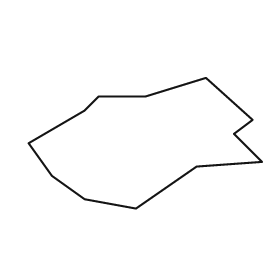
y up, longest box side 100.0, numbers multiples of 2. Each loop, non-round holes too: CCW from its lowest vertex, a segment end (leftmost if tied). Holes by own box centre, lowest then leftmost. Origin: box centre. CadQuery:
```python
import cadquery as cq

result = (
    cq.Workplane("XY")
    .moveTo(-4.0, -28.0)
    .lineTo(22.0, -10.0)
    .lineTo(50.0, -8.0)
    .lineTo(38.0, 4.0)
    .lineTo(46.0, 10.0)
    .lineTo(26.0, 28.0)
    .lineTo(0.0, 20.0)
    .lineTo(-20.0, 20.0)
    .lineTo(-26.0, 14.0)
    .lineTo(-50.0, 0.0)
    .lineTo(-40.0, -14.0)
    .lineTo(-26.0, -24.0)
    .close()
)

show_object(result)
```